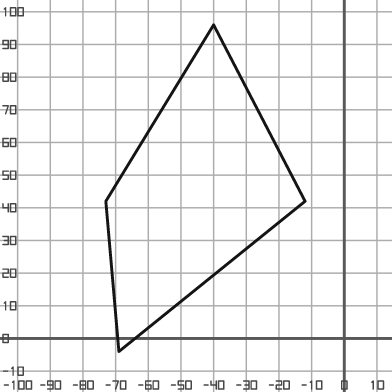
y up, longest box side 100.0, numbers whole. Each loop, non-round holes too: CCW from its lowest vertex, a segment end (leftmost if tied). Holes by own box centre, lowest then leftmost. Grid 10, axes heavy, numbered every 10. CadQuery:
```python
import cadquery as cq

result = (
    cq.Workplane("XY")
    .moveTo(-69.0, -4.0)
    .lineTo(-12.0, 42.0)
    .lineTo(-40.0, 96.0)
    .lineTo(-73.0, 42.0)
    .close()
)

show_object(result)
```